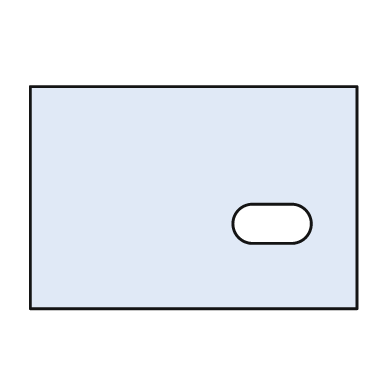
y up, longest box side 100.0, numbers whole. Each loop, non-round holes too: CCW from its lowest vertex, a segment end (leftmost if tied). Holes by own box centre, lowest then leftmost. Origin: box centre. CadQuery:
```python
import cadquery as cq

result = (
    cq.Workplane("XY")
    .moveTo(-50.0, -34.0)
    .lineTo(50.0, -34.0)
    .lineTo(50.0, 34.0)
    .lineTo(-50.0, 34.0)
    .close()
    .moveTo(18.0, -14.0)
    .lineTo(30.0, -14.0)
    .threePointArc((36.0, -8.0), (30.0, -2.0))
    .lineTo(18.0, -2.0)
    .threePointArc((12.0, -8.0), (18.0, -14.0))
    .close()
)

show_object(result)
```